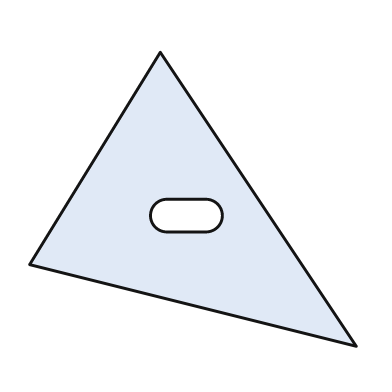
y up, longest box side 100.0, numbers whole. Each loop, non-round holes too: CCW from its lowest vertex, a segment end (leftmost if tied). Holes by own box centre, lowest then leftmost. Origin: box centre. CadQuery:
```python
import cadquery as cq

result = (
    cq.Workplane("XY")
    .moveTo(50.0, -45.0)
    .lineTo(-10.0, 45.0)
    .lineTo(-50.0, -20.0)
    .close()
    .moveTo(-8.0, -10.0)
    .lineTo(4.0, -10.0)
    .threePointArc((9.0, -5.0), (4.0, 0.0))
    .lineTo(-8.0, 0.0)
    .threePointArc((-13.0, -5.0), (-8.0, -10.0))
    .close()
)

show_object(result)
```